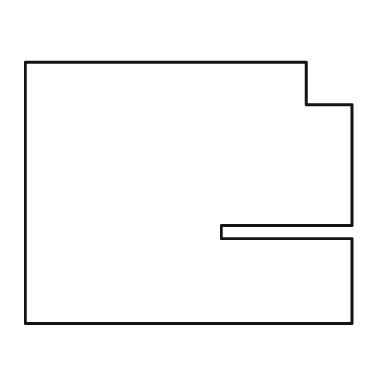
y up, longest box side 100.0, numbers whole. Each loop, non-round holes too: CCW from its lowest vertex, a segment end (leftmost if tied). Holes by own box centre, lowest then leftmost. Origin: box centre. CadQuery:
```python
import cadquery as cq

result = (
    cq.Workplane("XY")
    .moveTo(-50.0, -40.0)
    .lineTo(50.0, -40.0)
    .lineTo(50.0, -14.0)
    .lineTo(10.0, -14.0)
    .lineTo(10.0, -10.0)
    .lineTo(50.0, -10.0)
    .lineTo(50.0, 27.0)
    .lineTo(36.0, 27.0)
    .lineTo(36.0, 40.0)
    .lineTo(-50.0, 40.0)
    .close()
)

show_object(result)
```